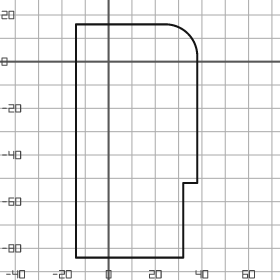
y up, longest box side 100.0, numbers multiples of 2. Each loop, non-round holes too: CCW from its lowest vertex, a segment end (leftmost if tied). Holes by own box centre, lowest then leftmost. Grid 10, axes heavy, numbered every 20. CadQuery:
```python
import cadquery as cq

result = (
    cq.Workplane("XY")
    .moveTo(-14.0, -84.0)
    .lineTo(32.0, -84.0)
    .lineTo(32.0, -52.0)
    .lineTo(38.0, -52.0)
    .lineTo(38.0, 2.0)
    .threePointArc((34.0, 12.0), (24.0, 16.0))
    .lineTo(-14.0, 16.0)
    .close()
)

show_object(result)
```